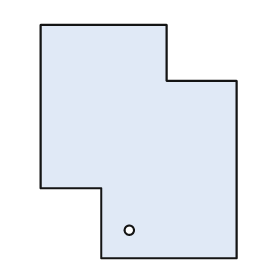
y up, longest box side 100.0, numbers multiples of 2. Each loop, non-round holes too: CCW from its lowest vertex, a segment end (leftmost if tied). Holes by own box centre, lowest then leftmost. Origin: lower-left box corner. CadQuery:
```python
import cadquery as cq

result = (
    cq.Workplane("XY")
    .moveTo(26.0, 0.0)
    .lineTo(84.0, 0.0)
    .lineTo(84.0, 76.0)
    .lineTo(54.0, 76.0)
    .lineTo(54.0, 100.0)
    .lineTo(0.0, 100.0)
    .lineTo(0.0, 30.0)
    .lineTo(26.0, 30.0)
    .close()
    .moveTo(38.0, 12.0)
    .circle(2.0)
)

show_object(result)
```